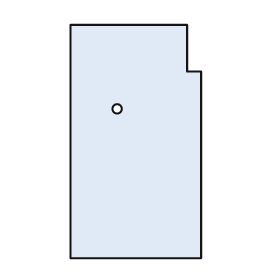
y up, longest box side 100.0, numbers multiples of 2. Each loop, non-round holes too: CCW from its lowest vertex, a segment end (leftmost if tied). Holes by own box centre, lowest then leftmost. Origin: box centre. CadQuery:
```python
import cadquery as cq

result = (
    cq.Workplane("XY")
    .moveTo(-28.0, -50.0)
    .lineTo(28.0, -50.0)
    .lineTo(28.0, 30.0)
    .lineTo(22.0, 30.0)
    .lineTo(22.0, 50.0)
    .lineTo(-28.0, 50.0)
    .close()
    .moveTo(-8.0, 14.0)
    .circle(2.0)
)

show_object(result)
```